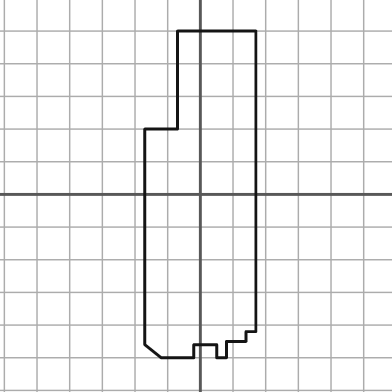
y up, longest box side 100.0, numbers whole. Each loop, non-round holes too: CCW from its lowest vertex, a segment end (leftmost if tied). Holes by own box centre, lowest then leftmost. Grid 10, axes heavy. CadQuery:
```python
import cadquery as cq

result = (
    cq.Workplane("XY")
    .moveTo(-12.0, -50.0)
    .lineTo(-2.0, -50.0)
    .lineTo(-2.0, -46.0)
    .lineTo(5.0, -46.0)
    .lineTo(5.0, -50.0)
    .lineTo(8.0, -50.0)
    .lineTo(8.0, -45.0)
    .lineTo(14.0, -45.0)
    .lineTo(14.0, -42.0)
    .lineTo(17.0, -42.0)
    .lineTo(17.0, 50.0)
    .lineTo(-7.0, 50.0)
    .lineTo(-7.0, 20.0)
    .lineTo(-17.0, 20.0)
    .lineTo(-17.0, -46.0)
    .close()
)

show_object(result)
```